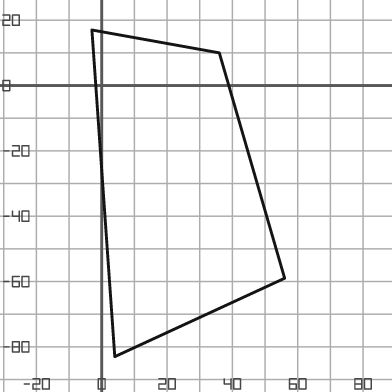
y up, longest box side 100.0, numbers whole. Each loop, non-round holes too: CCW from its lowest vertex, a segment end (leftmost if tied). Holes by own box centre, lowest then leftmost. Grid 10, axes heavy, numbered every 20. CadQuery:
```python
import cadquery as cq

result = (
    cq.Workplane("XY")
    .moveTo(4.0, -83.0)
    .lineTo(56.0, -59.0)
    .lineTo(36.0, 10.0)
    .lineTo(-3.0, 17.0)
    .close()
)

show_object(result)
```